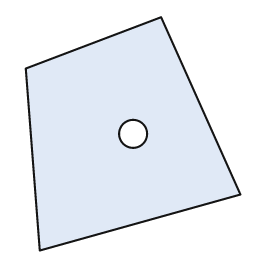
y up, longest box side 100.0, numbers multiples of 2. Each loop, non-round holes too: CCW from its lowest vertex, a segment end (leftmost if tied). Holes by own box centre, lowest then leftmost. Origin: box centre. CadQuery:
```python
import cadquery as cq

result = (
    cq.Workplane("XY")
    .moveTo(-40.0, -50.0)
    .lineTo(46.0, -26.0)
    .lineTo(12.0, 50.0)
    .lineTo(-46.0, 28.0)
    .close()
    .moveTo(0.0, 0.0)
    .circle(6.0)
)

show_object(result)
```